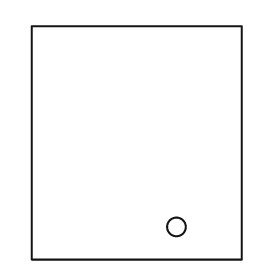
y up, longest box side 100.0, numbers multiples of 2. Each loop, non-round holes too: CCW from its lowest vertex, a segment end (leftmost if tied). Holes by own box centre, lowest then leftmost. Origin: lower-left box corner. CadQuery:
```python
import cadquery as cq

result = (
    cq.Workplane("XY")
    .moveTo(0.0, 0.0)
    .lineTo(90.0, 0.0)
    .lineTo(90.0, 100.0)
    .lineTo(0.0, 100.0)
    .close()
    .moveTo(62.0, 14.0)
    .circle(4.0)
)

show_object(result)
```